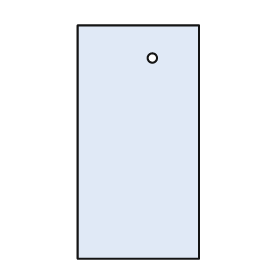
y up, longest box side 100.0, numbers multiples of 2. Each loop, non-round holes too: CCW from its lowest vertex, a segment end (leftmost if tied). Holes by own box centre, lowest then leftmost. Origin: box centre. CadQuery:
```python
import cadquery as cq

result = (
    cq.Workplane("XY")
    .moveTo(-26.0, -50.0)
    .lineTo(26.0, -50.0)
    .lineTo(26.0, 50.0)
    .lineTo(-26.0, 50.0)
    .close()
    .moveTo(6.0, 36.0)
    .circle(2.0)
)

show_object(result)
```